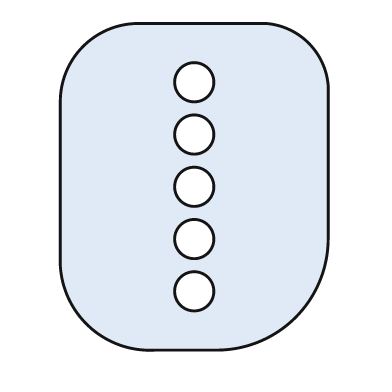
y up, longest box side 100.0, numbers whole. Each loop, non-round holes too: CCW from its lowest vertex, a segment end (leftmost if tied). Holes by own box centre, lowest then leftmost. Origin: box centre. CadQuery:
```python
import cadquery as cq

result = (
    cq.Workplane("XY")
    .moveTo(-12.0, -50.0)
    .lineTo(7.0, -50.0)
    .threePointArc((31.0, -40.0), (41.0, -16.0))
    .lineTo(41.0, 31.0)
    .threePointArc((35.0, 44.0), (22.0, 50.0))
    .lineTo(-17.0, 50.0)
    .threePointArc((-34.0, 43.0), (-41.0, 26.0))
    .lineTo(-41.0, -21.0)
    .threePointArc((-33.0, -42.0), (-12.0, -50.0))
    .close()
    .moveTo(0.0, -32.0)
    .circle(6.0)
    .moveTo(0.0, -16.0)
    .circle(6.0)
    .moveTo(0.0, 0.0)
    .circle(6.0)
    .moveTo(0.0, 16.0)
    .circle(6.0)
    .moveTo(0.0, 32.0)
    .circle(6.0)
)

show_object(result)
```